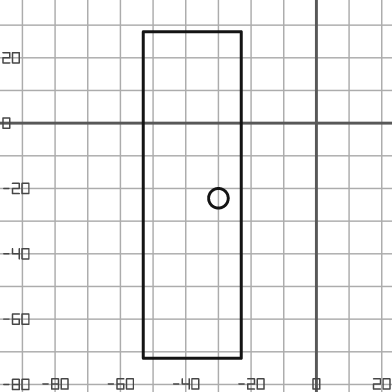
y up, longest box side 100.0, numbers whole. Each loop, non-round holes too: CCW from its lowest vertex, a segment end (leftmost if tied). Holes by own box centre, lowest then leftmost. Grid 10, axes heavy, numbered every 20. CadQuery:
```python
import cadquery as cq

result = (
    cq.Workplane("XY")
    .moveTo(-53.0, -72.0)
    .lineTo(-23.0, -72.0)
    .lineTo(-23.0, 28.0)
    .lineTo(-53.0, 28.0)
    .close()
    .moveTo(-30.0, -23.0)
    .circle(3.0)
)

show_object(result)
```